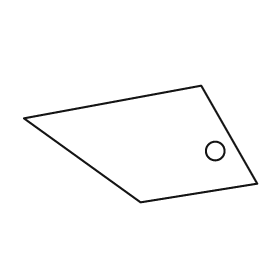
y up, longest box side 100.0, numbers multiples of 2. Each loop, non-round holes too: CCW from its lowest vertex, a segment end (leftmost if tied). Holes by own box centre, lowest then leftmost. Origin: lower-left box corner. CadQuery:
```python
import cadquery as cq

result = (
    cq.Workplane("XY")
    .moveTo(50.0, 0.0)
    .lineTo(100.0, 8.0)
    .lineTo(76.0, 50.0)
    .lineTo(0.0, 36.0)
    .close()
    .moveTo(82.0, 22.0)
    .circle(4.0)
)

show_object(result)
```